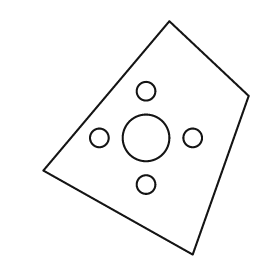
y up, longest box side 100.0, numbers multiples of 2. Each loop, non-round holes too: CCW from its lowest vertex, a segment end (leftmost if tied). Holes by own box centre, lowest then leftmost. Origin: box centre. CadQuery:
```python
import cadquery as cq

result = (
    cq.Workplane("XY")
    .moveTo(20.0, -50.0)
    .lineTo(44.0, 18.0)
    .lineTo(10.0, 50.0)
    .lineTo(-44.0, -14.0)
    .close()
    .moveTo(0.0, -20.0)
    .circle(4.0)
    .moveTo(-20.0, 0.0)
    .circle(4.0)
    .moveTo(0.0, 0.0)
    .circle(10.0)
    .moveTo(20.0, 0.0)
    .circle(4.0)
    .moveTo(0.0, 20.0)
    .circle(4.0)
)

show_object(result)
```